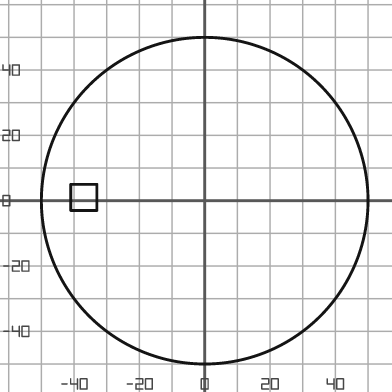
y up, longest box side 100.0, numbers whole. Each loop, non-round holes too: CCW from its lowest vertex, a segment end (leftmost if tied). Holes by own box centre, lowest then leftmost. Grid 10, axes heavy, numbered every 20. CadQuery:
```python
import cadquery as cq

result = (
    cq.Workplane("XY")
    .moveTo(0.0, 0.0)
    .circle(50.0)
    .moveTo(-41.0, -3.0)
    .lineTo(-33.0, -3.0)
    .lineTo(-33.0, 5.0)
    .lineTo(-41.0, 5.0)
    .close()
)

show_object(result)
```